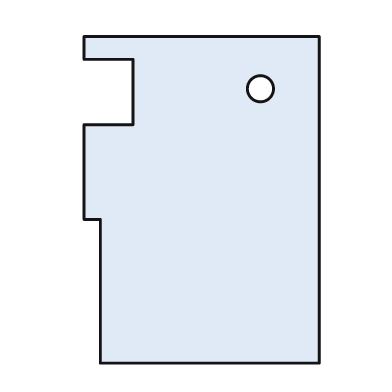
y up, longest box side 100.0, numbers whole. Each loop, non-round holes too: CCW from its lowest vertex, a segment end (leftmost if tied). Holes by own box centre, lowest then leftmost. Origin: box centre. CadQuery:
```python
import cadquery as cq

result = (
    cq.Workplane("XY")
    .moveTo(-31.0, -50.0)
    .lineTo(36.0, -50.0)
    .lineTo(36.0, 50.0)
    .lineTo(-36.0, 50.0)
    .lineTo(-36.0, 43.0)
    .lineTo(-21.0, 43.0)
    .lineTo(-21.0, 23.0)
    .lineTo(-36.0, 23.0)
    .lineTo(-36.0, -6.0)
    .lineTo(-31.0, -6.0)
    .close()
    .moveTo(18.0, 34.0)
    .circle(4.0)
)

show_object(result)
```